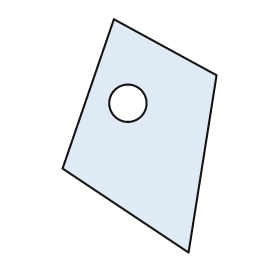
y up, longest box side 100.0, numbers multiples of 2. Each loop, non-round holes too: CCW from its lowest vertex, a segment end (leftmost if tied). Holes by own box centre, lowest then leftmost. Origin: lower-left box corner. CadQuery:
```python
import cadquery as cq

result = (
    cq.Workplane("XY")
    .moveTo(54.0, 0.0)
    .lineTo(66.0, 76.0)
    .lineTo(22.0, 100.0)
    .lineTo(0.0, 36.0)
    .close()
    .moveTo(28.0, 64.0)
    .circle(8.0)
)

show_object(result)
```